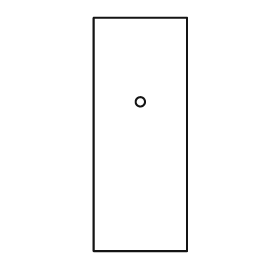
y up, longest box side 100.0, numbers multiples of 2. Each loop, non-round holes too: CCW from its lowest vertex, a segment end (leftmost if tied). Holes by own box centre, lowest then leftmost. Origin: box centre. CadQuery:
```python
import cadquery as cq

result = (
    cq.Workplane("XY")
    .moveTo(-20.0, -50.0)
    .lineTo(20.0, -50.0)
    .lineTo(20.0, 50.0)
    .lineTo(-20.0, 50.0)
    .close()
    .moveTo(0.0, 14.0)
    .circle(2.0)
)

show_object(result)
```